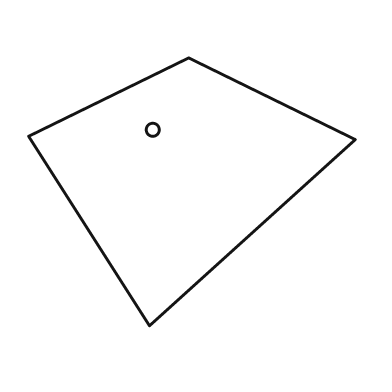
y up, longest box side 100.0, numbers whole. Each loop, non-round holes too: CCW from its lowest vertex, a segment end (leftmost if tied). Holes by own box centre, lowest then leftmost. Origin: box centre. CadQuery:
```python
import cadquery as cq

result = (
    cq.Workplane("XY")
    .moveTo(-13.0, -41.0)
    .lineTo(50.0, 16.0)
    .lineTo(-1.0, 41.0)
    .lineTo(-50.0, 17.0)
    .close()
    .moveTo(-12.0, 19.0)
    .circle(2.0)
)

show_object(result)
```